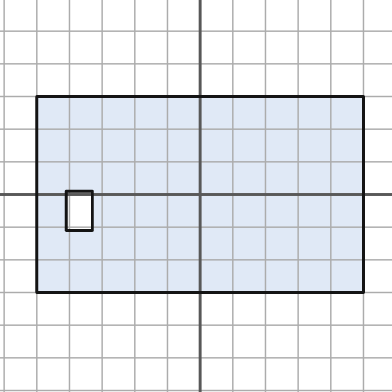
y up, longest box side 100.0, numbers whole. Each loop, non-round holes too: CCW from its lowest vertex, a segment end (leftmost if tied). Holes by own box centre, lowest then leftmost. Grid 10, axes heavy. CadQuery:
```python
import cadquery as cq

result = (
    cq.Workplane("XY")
    .moveTo(-50.0, -30.0)
    .lineTo(50.0, -30.0)
    .lineTo(50.0, 30.0)
    .lineTo(-50.0, 30.0)
    .close()
    .moveTo(-41.0, -11.0)
    .lineTo(-33.0, -11.0)
    .lineTo(-33.0, 1.0)
    .lineTo(-41.0, 1.0)
    .close()
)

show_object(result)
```